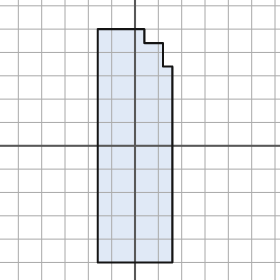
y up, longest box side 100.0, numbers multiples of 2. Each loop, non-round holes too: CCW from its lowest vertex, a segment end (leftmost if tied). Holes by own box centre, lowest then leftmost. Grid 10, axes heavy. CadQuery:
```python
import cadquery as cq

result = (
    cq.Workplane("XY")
    .moveTo(-16.0, -50.0)
    .lineTo(16.0, -50.0)
    .lineTo(16.0, 34.0)
    .lineTo(12.0, 34.0)
    .lineTo(12.0, 44.0)
    .lineTo(4.0, 44.0)
    .lineTo(4.0, 50.0)
    .lineTo(-16.0, 50.0)
    .close()
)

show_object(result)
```